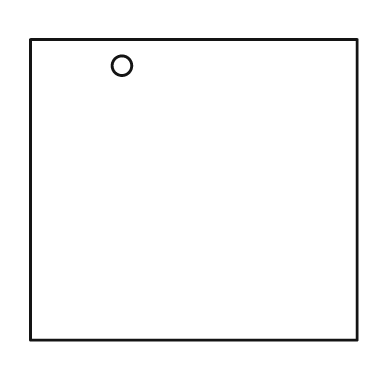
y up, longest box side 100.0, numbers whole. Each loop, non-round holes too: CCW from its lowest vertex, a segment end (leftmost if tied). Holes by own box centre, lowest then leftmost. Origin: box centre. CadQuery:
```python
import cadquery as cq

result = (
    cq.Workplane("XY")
    .moveTo(-50.0, -46.0)
    .lineTo(50.0, -46.0)
    .lineTo(50.0, 46.0)
    .lineTo(-50.0, 46.0)
    .close()
    .moveTo(-22.0, 38.0)
    .circle(3.0)
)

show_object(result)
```